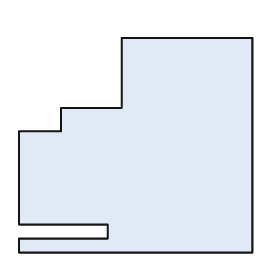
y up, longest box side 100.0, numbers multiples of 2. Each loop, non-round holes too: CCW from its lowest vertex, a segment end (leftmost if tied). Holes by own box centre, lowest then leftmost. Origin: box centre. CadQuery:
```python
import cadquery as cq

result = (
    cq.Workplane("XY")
    .moveTo(-50.0, -46.0)
    .lineTo(50.0, -46.0)
    .lineTo(50.0, 46.0)
    .lineTo(-6.0, 46.0)
    .lineTo(-6.0, 16.0)
    .lineTo(-32.0, 16.0)
    .lineTo(-32.0, 6.0)
    .lineTo(-50.0, 6.0)
    .lineTo(-50.0, -34.0)
    .lineTo(-12.0, -34.0)
    .lineTo(-12.0, -40.0)
    .lineTo(-50.0, -40.0)
    .close()
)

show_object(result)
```